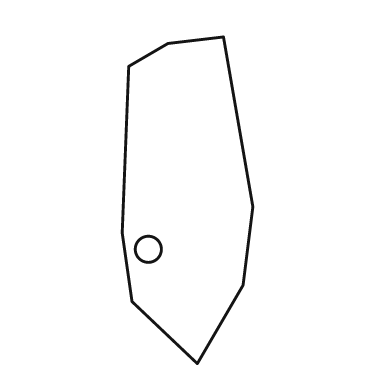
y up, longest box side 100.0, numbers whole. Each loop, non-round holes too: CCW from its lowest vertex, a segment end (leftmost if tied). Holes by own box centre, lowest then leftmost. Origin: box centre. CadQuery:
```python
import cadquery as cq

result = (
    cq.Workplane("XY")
    .moveTo(3.0, -50.0)
    .lineTo(17.0, -26.0)
    .lineTo(20.0, -2.0)
    .lineTo(11.0, 50.0)
    .lineTo(-6.0, 48.0)
    .lineTo(-18.0, 41.0)
    .lineTo(-20.0, -10.0)
    .lineTo(-17.0, -31.0)
    .close()
    .moveTo(-12.0, -15.0)
    .circle(4.0)
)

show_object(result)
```